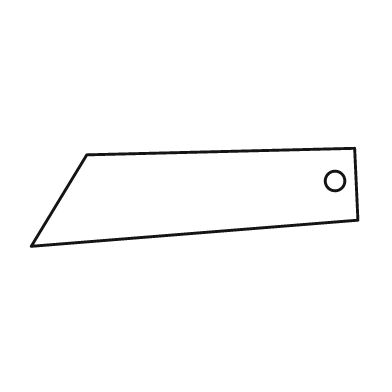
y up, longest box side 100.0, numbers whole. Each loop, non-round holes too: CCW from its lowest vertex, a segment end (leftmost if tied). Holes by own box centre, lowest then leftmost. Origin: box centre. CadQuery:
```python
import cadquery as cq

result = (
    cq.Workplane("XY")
    .moveTo(-50.0, -15.0)
    .lineTo(50.0, -7.0)
    .lineTo(49.0, 15.0)
    .lineTo(-33.0, 13.0)
    .close()
    .moveTo(43.0, 5.0)
    .circle(3.0)
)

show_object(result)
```